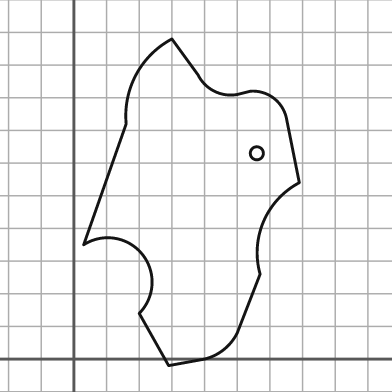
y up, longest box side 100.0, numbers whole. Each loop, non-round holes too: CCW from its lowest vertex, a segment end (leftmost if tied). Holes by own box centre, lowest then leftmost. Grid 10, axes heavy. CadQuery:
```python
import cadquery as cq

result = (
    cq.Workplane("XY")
    .moveTo(29.0, -2.0)
    .lineTo(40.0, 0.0)
    .threePointArc((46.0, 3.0), (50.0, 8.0))
    .lineTo(57.0, 26.0)
    .threePointArc((58.0, 42.0), (69.0, 54.0))
    .lineTo(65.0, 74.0)
    .threePointArc((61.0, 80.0), (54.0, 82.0))
    .lineTo(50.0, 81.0)
    .threePointArc((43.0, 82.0), (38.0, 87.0))
    .lineTo(30.0, 98.0)
    .threePointArc((19.0, 87.0), (16.0, 72.0))
    .lineTo(3.0, 35.0)
    .threePointArc((21.0, 32.0), (20.0, 14.0))
    .close()
    .moveTo(56.0, 63.0)
    .circle(2.0)
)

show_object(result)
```